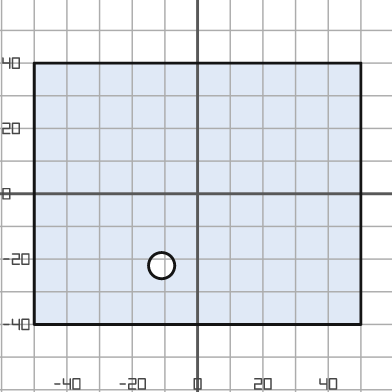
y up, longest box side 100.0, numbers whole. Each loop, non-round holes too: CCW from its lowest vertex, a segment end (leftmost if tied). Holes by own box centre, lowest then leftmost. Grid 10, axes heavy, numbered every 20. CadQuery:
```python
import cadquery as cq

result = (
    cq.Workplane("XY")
    .moveTo(-50.0, -40.0)
    .lineTo(50.0, -40.0)
    .lineTo(50.0, 40.0)
    .lineTo(-50.0, 40.0)
    .close()
    .moveTo(-11.0, -22.0)
    .circle(4.0)
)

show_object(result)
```